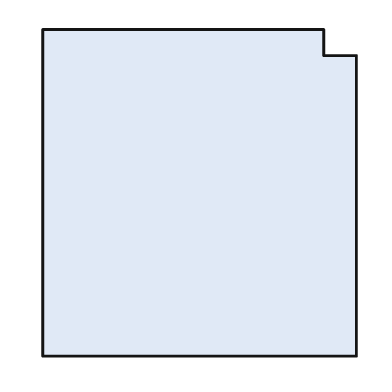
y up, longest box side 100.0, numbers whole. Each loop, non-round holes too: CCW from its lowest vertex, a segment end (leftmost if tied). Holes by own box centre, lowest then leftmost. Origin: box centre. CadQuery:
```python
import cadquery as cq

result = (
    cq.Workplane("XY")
    .moveTo(-48.0, -50.0)
    .lineTo(48.0, -50.0)
    .lineTo(48.0, 42.0)
    .lineTo(38.0, 42.0)
    .lineTo(38.0, 50.0)
    .lineTo(-48.0, 50.0)
    .close()
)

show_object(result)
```